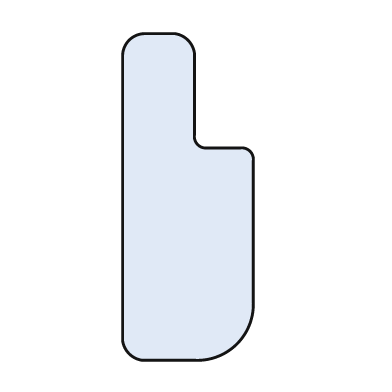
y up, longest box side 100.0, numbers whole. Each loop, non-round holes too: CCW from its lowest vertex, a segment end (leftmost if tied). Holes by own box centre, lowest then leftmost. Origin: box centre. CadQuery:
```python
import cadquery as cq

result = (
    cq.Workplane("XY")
    .moveTo(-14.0, -50.0)
    .lineTo(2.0, -50.0)
    .threePointArc((15.0, -45.0), (20.0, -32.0))
    .lineTo(20.0, 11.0)
    .threePointArc((19.0, 14.0), (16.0, 15.0))
    .lineTo(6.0, 15.0)
    .threePointArc((3.0, 16.0), (2.0, 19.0))
    .lineTo(2.0, 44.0)
    .threePointArc((0.0, 48.0), (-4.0, 50.0))
    .lineTo(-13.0, 50.0)
    .threePointArc((-18.0, 48.0), (-20.0, 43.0))
    .lineTo(-20.0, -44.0)
    .threePointArc((-18.0, -48.0), (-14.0, -50.0))
    .close()
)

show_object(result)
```